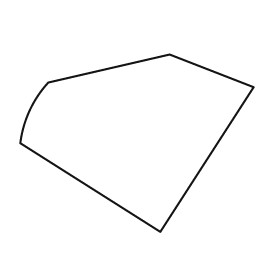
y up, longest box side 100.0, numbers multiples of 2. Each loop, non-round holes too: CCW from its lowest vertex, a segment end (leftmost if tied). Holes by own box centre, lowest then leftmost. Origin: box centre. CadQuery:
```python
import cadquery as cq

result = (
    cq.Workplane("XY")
    .moveTo(10.0, -38.0)
    .lineTo(50.0, 24.0)
    .lineTo(14.0, 38.0)
    .lineTo(-38.0, 26.0)
    .threePointArc((-46.0, 14.0), (-50.0, 0.0))
    .close()
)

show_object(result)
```